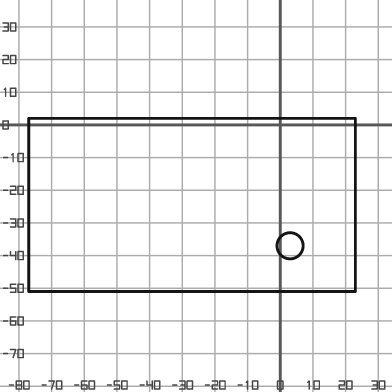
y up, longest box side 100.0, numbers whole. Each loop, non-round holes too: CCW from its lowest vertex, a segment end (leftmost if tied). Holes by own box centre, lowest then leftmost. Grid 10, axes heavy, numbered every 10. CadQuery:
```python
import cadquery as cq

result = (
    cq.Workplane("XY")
    .moveTo(-77.0, -51.0)
    .lineTo(23.0, -51.0)
    .lineTo(23.0, 2.0)
    .lineTo(-77.0, 2.0)
    .close()
    .moveTo(3.0, -37.0)
    .circle(4.0)
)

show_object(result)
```